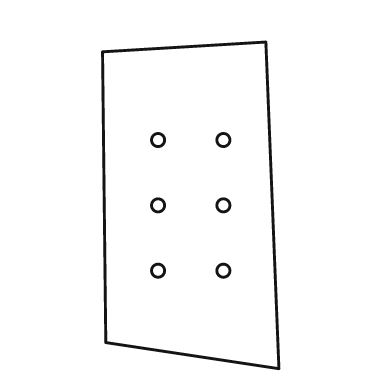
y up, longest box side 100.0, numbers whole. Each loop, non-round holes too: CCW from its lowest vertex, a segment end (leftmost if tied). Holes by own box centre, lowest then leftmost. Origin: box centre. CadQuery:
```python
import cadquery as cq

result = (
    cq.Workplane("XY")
    .moveTo(27.0, -50.0)
    .lineTo(23.0, 50.0)
    .lineTo(-27.0, 47.0)
    .lineTo(-26.0, -42.0)
    .close()
    .moveTo(-10.0, -20.0)
    .circle(2.0)
    .moveTo(10.0, -20.0)
    .circle(2.0)
    .moveTo(-10.0, 0.0)
    .circle(2.0)
    .moveTo(10.0, 0.0)
    .circle(2.0)
    .moveTo(-10.0, 20.0)
    .circle(2.0)
    .moveTo(10.0, 20.0)
    .circle(2.0)
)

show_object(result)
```